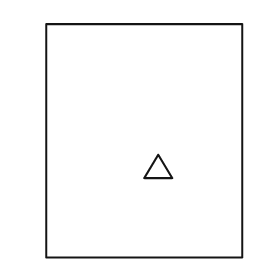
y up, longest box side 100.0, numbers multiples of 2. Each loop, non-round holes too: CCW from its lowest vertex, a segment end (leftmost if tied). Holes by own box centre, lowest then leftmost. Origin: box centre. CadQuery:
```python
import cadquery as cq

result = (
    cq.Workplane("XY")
    .moveTo(-42.0, -50.0)
    .lineTo(42.0, -50.0)
    .lineTo(42.0, 50.0)
    .lineTo(-42.0, 50.0)
    .close()
    .moveTo(0.0, -16.0)
    .lineTo(12.0, -16.0)
    .lineTo(6.0, -6.0)
    .close()
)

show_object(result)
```